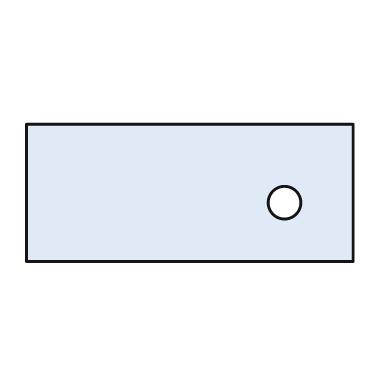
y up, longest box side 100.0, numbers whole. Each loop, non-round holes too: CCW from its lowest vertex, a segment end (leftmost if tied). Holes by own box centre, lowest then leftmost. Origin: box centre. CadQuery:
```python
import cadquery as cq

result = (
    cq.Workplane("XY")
    .moveTo(-50.0, -21.0)
    .lineTo(50.0, -21.0)
    .lineTo(50.0, 21.0)
    .lineTo(-50.0, 21.0)
    .close()
    .moveTo(29.0, -3.0)
    .circle(5.0)
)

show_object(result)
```